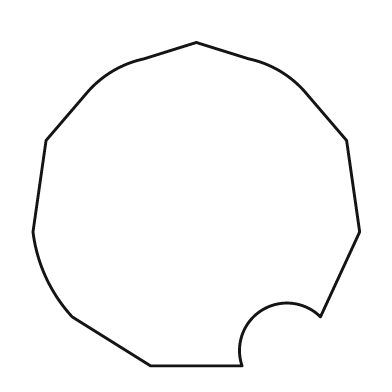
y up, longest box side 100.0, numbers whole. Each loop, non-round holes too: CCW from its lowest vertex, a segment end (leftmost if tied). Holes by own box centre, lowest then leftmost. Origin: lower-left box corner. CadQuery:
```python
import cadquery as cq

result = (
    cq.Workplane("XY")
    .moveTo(36.0, 0.0)
    .lineTo(64.0, 0.0)
    .threePointArc((70.0, 17.0), (88.0, 15.0))
    .lineTo(100.0, 41.0)
    .lineTo(96.0, 69.0)
    .lineTo(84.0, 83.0)
    .threePointArc((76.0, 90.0), (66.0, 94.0))
    .lineTo(50.0, 99.0)
    .lineTo(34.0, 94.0)
    .threePointArc((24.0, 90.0), (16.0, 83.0))
    .lineTo(4.0, 69.0)
    .lineTo(0.0, 41.0)
    .threePointArc((4.0, 27.0), (12.0, 15.0))
    .close()
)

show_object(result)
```